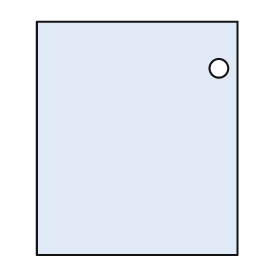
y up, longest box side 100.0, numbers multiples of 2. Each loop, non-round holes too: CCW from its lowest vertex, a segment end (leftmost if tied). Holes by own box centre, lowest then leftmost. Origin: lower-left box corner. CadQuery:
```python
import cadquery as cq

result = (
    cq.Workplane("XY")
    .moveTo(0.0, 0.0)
    .lineTo(86.0, 0.0)
    .lineTo(86.0, 100.0)
    .lineTo(0.0, 100.0)
    .close()
    .moveTo(78.0, 80.0)
    .circle(4.0)
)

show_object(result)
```